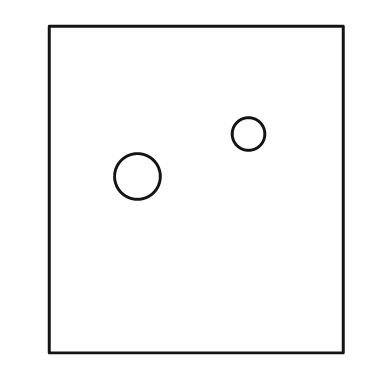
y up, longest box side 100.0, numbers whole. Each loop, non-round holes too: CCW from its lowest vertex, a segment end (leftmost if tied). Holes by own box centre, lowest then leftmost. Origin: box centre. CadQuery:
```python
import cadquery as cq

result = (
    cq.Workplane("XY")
    .moveTo(-45.0, -50.0)
    .lineTo(45.0, -50.0)
    .lineTo(45.0, 50.0)
    .lineTo(-45.0, 50.0)
    .close()
    .moveTo(-18.0, 4.0)
    .circle(7.0)
    .moveTo(16.0, 17.0)
    .circle(5.0)
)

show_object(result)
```